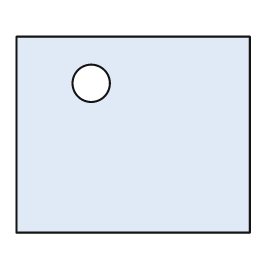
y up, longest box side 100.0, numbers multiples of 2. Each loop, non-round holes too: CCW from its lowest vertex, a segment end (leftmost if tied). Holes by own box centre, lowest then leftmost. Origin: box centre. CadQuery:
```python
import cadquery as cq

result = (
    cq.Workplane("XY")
    .moveTo(-50.0, -42.0)
    .lineTo(50.0, -42.0)
    .lineTo(50.0, 42.0)
    .lineTo(-50.0, 42.0)
    .close()
    .moveTo(-18.0, 22.0)
    .circle(8.0)
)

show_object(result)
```